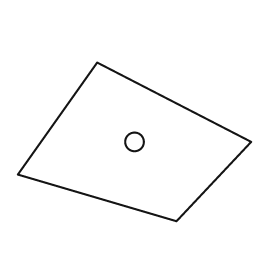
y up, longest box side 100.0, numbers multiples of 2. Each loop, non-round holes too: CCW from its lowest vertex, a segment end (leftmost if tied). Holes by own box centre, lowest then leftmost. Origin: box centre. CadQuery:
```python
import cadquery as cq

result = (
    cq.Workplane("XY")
    .moveTo(18.0, -34.0)
    .lineTo(50.0, 0.0)
    .lineTo(-16.0, 34.0)
    .lineTo(-50.0, -14.0)
    .close()
    .moveTo(0.0, 0.0)
    .circle(4.0)
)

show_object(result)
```